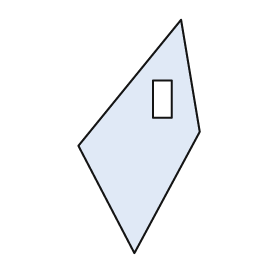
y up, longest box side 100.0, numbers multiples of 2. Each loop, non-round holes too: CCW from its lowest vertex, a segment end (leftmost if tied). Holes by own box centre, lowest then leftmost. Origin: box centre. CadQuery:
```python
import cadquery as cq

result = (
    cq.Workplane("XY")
    .moveTo(-2.0, -50.0)
    .lineTo(26.0, 2.0)
    .lineTo(18.0, 50.0)
    .lineTo(-26.0, -4.0)
    .close()
    .moveTo(6.0, 8.0)
    .lineTo(14.0, 8.0)
    .lineTo(14.0, 24.0)
    .lineTo(6.0, 24.0)
    .close()
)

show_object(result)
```